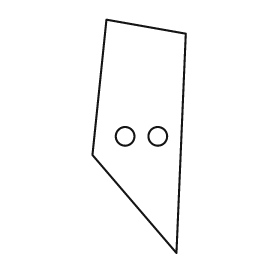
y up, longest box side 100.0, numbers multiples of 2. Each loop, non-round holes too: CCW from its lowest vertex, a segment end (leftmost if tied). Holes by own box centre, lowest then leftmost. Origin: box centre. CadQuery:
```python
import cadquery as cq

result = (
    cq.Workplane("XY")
    .moveTo(16.0, -50.0)
    .lineTo(20.0, 44.0)
    .lineTo(-14.0, 50.0)
    .lineTo(-20.0, -8.0)
    .close()
    .moveTo(-6.0, 0.0)
    .circle(4.0)
    .moveTo(8.0, 0.0)
    .circle(4.0)
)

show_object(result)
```